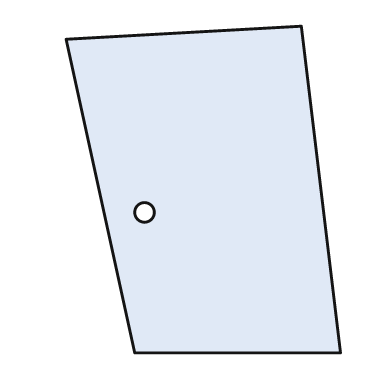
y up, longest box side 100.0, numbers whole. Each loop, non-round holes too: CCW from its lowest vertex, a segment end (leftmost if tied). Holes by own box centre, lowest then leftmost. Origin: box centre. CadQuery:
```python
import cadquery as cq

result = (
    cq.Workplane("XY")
    .moveTo(-21.0, -50.0)
    .lineTo(42.0, -50.0)
    .lineTo(30.0, 50.0)
    .lineTo(-42.0, 46.0)
    .close()
    .moveTo(-18.0, -7.0)
    .circle(3.0)
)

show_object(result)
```